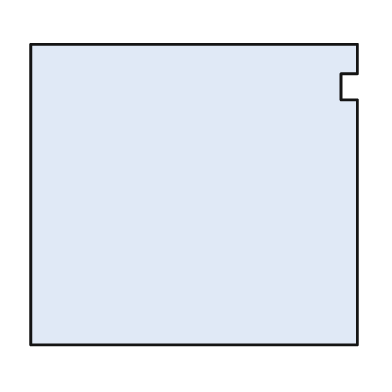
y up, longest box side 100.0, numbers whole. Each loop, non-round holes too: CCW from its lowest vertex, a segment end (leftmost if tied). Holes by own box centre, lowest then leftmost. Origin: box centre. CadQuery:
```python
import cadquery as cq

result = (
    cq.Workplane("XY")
    .moveTo(-50.0, -46.0)
    .lineTo(50.0, -46.0)
    .lineTo(50.0, 29.0)
    .lineTo(45.0, 29.0)
    .lineTo(45.0, 37.0)
    .lineTo(50.0, 37.0)
    .lineTo(50.0, 46.0)
    .lineTo(-50.0, 46.0)
    .close()
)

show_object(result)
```